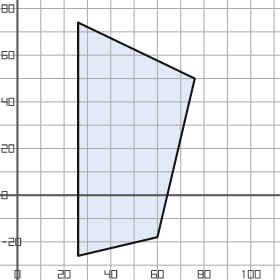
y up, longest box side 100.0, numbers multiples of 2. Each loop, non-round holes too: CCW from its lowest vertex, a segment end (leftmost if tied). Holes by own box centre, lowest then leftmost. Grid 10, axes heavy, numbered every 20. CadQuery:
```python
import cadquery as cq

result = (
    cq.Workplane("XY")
    .moveTo(26.0, -26.0)
    .lineTo(60.0, -18.0)
    .lineTo(76.0, 50.0)
    .lineTo(26.0, 74.0)
    .close()
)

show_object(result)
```